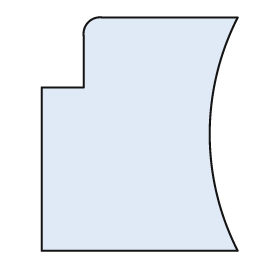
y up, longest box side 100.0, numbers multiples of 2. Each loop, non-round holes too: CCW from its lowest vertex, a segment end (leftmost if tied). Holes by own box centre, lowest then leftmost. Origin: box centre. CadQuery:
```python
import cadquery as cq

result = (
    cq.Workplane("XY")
    .moveTo(-42.0, -50.0)
    .lineTo(42.0, -50.0)
    .threePointArc((30.0, 0.0), (42.0, 50.0))
    .lineTo(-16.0, 50.0)
    .threePointArc((-22.0, 48.0), (-24.0, 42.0))
    .lineTo(-24.0, 20.0)
    .lineTo(-42.0, 20.0)
    .close()
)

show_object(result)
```